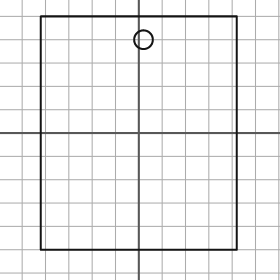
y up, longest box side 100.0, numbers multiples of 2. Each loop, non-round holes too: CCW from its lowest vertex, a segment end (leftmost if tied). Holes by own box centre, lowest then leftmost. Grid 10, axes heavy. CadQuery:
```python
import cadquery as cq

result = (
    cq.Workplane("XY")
    .moveTo(-42.0, -50.0)
    .lineTo(42.0, -50.0)
    .lineTo(42.0, 50.0)
    .lineTo(-42.0, 50.0)
    .close()
    .moveTo(2.0, 40.0)
    .circle(4.0)
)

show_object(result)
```